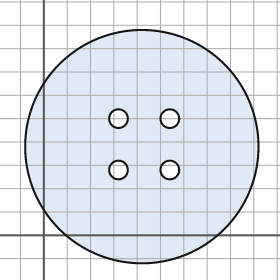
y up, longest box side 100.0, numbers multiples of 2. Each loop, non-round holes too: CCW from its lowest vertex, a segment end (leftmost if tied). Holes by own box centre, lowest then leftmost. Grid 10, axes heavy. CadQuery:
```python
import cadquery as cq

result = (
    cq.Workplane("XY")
    .moveTo(42.0, 38.0)
    .circle(50.0)
    .moveTo(32.0, 28.0)
    .circle(4.0)
    .moveTo(54.0, 28.0)
    .circle(4.0)
    .moveTo(32.0, 50.0)
    .circle(4.0)
    .moveTo(54.0, 50.0)
    .circle(4.0)
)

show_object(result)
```